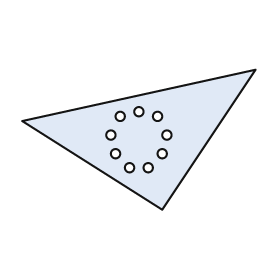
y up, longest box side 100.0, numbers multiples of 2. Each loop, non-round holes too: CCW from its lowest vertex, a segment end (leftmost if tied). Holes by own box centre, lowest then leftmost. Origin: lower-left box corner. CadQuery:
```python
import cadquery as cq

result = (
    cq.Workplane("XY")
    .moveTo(60.0, 0.0)
    .lineTo(100.0, 60.0)
    .lineTo(0.0, 38.0)
    .close()
    .moveTo(46.0, 18.0)
    .circle(2.0)
    .moveTo(54.0, 18.0)
    .circle(2.0)
    .moveTo(40.0, 24.0)
    .circle(2.0)
    .moveTo(60.0, 24.0)
    .circle(2.0)
    .moveTo(38.0, 32.0)
    .circle(2.0)
    .moveTo(62.0, 32.0)
    .circle(2.0)
    .moveTo(42.0, 40.0)
    .circle(2.0)
    .moveTo(58.0, 40.0)
    .circle(2.0)
    .moveTo(50.0, 42.0)
    .circle(2.0)
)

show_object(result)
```